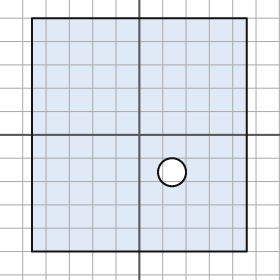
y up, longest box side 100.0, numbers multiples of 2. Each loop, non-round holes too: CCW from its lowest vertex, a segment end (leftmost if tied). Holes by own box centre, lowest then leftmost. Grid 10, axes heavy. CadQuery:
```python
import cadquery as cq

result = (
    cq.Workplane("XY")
    .moveTo(-46.0, -50.0)
    .lineTo(46.0, -50.0)
    .lineTo(46.0, 50.0)
    .lineTo(-46.0, 50.0)
    .close()
    .moveTo(14.0, -16.0)
    .circle(6.0)
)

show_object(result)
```